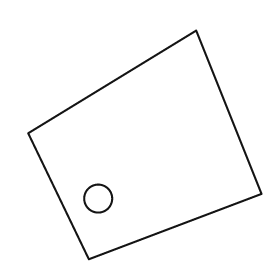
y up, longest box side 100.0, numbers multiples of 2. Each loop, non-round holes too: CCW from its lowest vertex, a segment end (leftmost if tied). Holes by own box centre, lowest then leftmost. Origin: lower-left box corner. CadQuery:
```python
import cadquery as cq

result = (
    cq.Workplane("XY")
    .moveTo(26.0, 0.0)
    .lineTo(100.0, 28.0)
    .lineTo(72.0, 98.0)
    .lineTo(0.0, 54.0)
    .close()
    .moveTo(30.0, 26.0)
    .circle(6.0)
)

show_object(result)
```